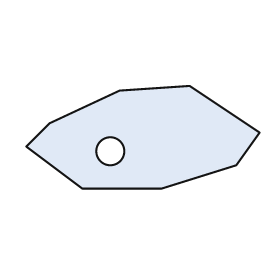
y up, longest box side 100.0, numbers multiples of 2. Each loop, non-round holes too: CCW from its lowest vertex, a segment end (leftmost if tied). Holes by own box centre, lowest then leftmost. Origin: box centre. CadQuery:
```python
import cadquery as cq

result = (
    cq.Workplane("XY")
    .moveTo(-26.0, -22.0)
    .lineTo(8.0, -22.0)
    .lineTo(40.0, -12.0)
    .lineTo(50.0, 2.0)
    .lineTo(20.0, 22.0)
    .lineTo(-10.0, 20.0)
    .lineTo(-40.0, 6.0)
    .lineTo(-50.0, -4.0)
    .close()
    .moveTo(-14.0, -6.0)
    .circle(6.0)
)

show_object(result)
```